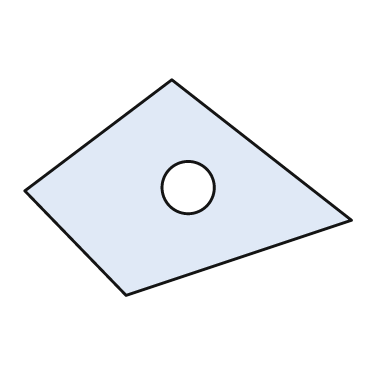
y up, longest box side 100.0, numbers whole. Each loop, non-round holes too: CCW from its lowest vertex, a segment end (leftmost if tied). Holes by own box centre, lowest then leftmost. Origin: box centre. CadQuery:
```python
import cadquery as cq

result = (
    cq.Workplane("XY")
    .moveTo(-19.0, -33.0)
    .lineTo(50.0, -10.0)
    .lineTo(-5.0, 33.0)
    .lineTo(-50.0, -1.0)
    .close()
    .moveTo(0.0, 0.0)
    .circle(8.0)
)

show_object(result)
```